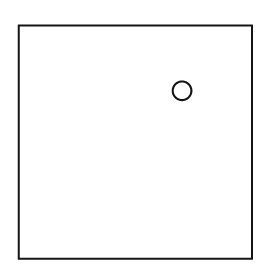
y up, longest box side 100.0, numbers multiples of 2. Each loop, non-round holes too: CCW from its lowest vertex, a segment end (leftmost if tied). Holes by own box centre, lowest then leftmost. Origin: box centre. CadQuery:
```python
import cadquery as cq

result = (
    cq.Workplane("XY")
    .moveTo(-50.0, -50.0)
    .lineTo(50.0, -50.0)
    .lineTo(50.0, 50.0)
    .lineTo(-50.0, 50.0)
    .close()
    .moveTo(20.0, 22.0)
    .circle(4.0)
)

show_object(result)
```